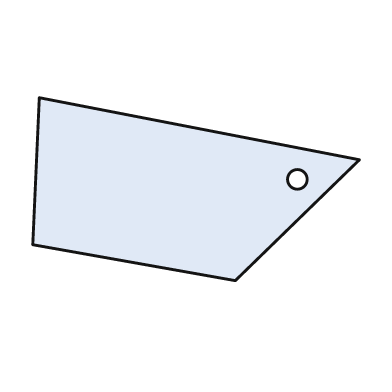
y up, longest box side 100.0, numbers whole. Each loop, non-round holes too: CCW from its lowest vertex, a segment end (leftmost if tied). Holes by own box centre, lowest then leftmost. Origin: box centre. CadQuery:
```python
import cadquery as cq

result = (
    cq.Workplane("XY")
    .moveTo(12.0, -28.0)
    .lineTo(50.0, 9.0)
    .lineTo(-48.0, 28.0)
    .lineTo(-50.0, -17.0)
    .close()
    .moveTo(31.0, 3.0)
    .circle(3.0)
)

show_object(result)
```